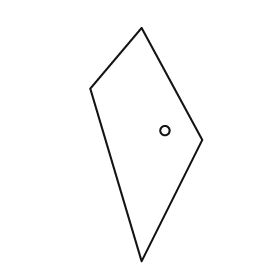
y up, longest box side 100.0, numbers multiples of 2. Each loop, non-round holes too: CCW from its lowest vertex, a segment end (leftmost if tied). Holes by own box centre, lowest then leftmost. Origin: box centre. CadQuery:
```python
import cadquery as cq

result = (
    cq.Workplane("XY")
    .moveTo(-2.0, -50.0)
    .lineTo(24.0, 2.0)
    .lineTo(-2.0, 50.0)
    .lineTo(-24.0, 24.0)
    .close()
    .moveTo(8.0, 6.0)
    .circle(2.0)
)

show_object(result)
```